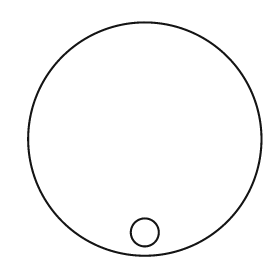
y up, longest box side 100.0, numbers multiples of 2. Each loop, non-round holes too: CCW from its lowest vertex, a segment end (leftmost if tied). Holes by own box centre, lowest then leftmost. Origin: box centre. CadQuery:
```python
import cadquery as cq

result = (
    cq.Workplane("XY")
    .moveTo(0.0, 0.0)
    .circle(50.0)
    .moveTo(0.0, -40.0)
    .circle(6.0)
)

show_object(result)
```